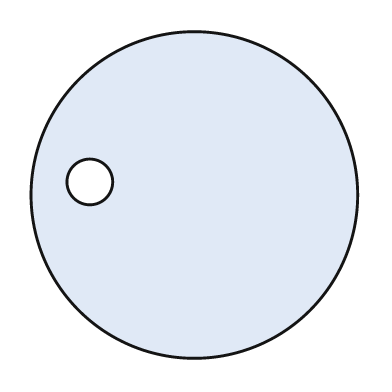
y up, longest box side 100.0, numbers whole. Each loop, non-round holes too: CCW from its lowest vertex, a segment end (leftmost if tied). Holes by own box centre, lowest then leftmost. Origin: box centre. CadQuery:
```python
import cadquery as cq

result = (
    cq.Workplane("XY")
    .moveTo(0.0, 0.0)
    .circle(50.0)
    .moveTo(-32.0, 4.0)
    .circle(7.0)
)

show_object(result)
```